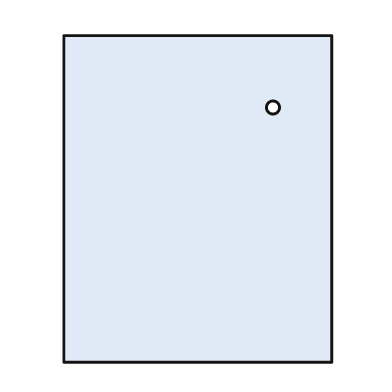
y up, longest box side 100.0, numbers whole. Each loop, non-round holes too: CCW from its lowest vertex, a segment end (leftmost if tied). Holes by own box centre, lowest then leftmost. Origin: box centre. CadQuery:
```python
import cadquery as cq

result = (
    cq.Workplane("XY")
    .moveTo(-41.0, -50.0)
    .lineTo(41.0, -50.0)
    .lineTo(41.0, 50.0)
    .lineTo(-41.0, 50.0)
    .close()
    .moveTo(23.0, 28.0)
    .circle(2.0)
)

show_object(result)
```